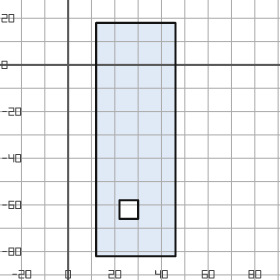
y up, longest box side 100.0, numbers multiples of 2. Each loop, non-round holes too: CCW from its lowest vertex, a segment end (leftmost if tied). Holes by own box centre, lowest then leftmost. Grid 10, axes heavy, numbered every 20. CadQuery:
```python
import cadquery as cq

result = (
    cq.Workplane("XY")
    .moveTo(12.0, -82.0)
    .lineTo(46.0, -82.0)
    .lineTo(46.0, 18.0)
    .lineTo(12.0, 18.0)
    .close()
    .moveTo(22.0, -66.0)
    .lineTo(30.0, -66.0)
    .lineTo(30.0, -58.0)
    .lineTo(22.0, -58.0)
    .close()
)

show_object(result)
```